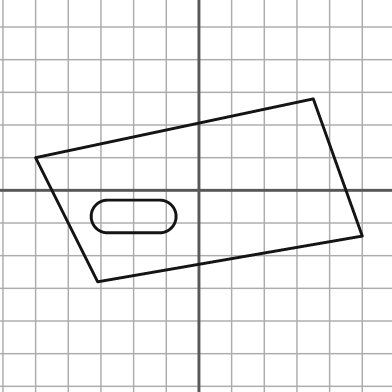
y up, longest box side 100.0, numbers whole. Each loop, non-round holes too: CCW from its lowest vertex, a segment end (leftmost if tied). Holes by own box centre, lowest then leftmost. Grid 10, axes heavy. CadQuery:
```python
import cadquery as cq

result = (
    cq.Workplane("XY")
    .moveTo(-31.0, -28.0)
    .lineTo(50.0, -14.0)
    .lineTo(35.0, 28.0)
    .lineTo(-50.0, 10.0)
    .close()
    .moveTo(-28.0, -13.0)
    .lineTo(-12.0, -13.0)
    .threePointArc((-7.0, -8.0), (-12.0, -3.0))
    .lineTo(-28.0, -3.0)
    .threePointArc((-33.0, -8.0), (-28.0, -13.0))
    .close()
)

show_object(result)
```